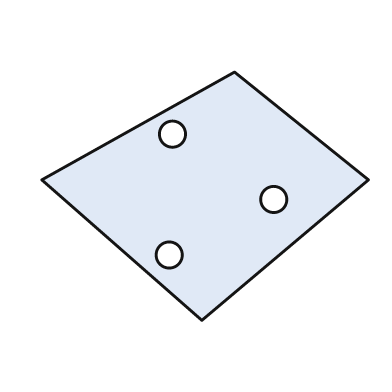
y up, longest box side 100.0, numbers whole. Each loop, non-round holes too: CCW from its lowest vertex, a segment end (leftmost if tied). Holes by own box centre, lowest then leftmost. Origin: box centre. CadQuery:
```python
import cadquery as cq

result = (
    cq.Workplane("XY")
    .moveTo(-1.0, -38.0)
    .lineTo(50.0, 5.0)
    .lineTo(9.0, 38.0)
    .lineTo(-50.0, 5.0)
    .close()
    .moveTo(-11.0, -18.0)
    .circle(4.0)
    .moveTo(21.0, -1.0)
    .circle(4.0)
    .moveTo(-10.0, 19.0)
    .circle(4.0)
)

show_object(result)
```